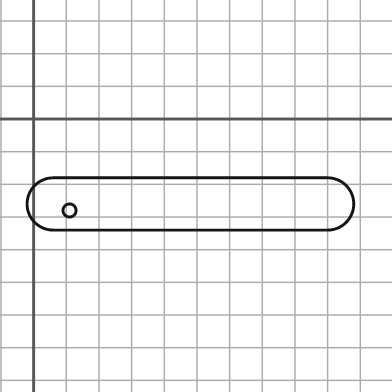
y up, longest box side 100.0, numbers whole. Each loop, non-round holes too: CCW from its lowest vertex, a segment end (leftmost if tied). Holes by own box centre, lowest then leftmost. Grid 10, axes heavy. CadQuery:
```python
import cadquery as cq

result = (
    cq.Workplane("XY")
    .moveTo(6.0, -34.0)
    .lineTo(90.0, -34.0)
    .threePointArc((98.0, -26.0), (90.0, -18.0))
    .lineTo(6.0, -18.0)
    .threePointArc((-2.0, -26.0), (6.0, -34.0))
    .close()
    .moveTo(11.0, -28.0)
    .circle(2.0)
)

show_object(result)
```